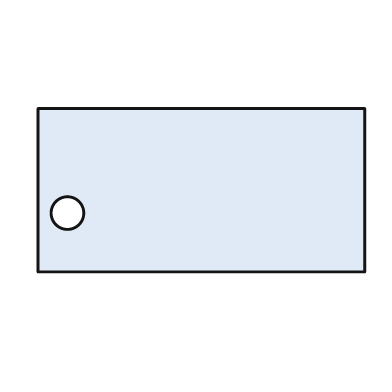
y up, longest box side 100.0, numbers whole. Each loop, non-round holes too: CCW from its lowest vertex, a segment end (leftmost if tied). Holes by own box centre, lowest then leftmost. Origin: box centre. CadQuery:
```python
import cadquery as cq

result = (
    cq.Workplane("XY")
    .moveTo(-50.0, -25.0)
    .lineTo(50.0, -25.0)
    .lineTo(50.0, 25.0)
    .lineTo(-50.0, 25.0)
    .close()
    .moveTo(-41.0, -7.0)
    .circle(5.0)
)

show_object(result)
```